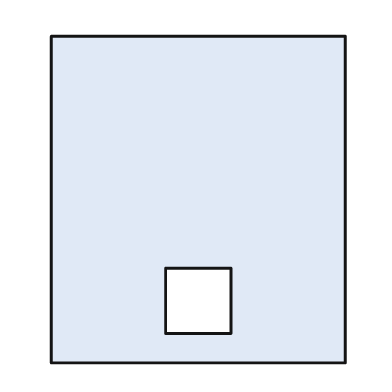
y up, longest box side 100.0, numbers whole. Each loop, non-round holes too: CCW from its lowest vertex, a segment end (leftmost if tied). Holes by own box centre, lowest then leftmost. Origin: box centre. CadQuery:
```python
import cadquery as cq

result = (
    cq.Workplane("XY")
    .moveTo(-45.0, -50.0)
    .lineTo(45.0, -50.0)
    .lineTo(45.0, 50.0)
    .lineTo(-45.0, 50.0)
    .close()
    .moveTo(-10.0, -41.0)
    .lineTo(10.0, -41.0)
    .lineTo(10.0, -21.0)
    .lineTo(-10.0, -21.0)
    .close()
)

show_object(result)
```